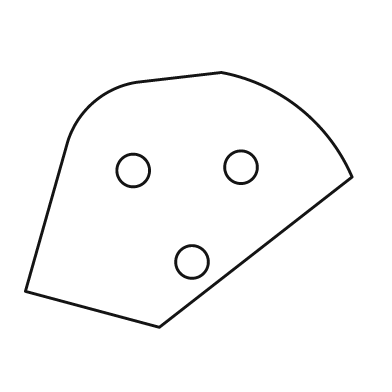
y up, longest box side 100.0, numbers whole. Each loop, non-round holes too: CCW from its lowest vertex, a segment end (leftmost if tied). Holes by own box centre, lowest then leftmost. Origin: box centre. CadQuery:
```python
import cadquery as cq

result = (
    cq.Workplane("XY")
    .moveTo(-9.0, -39.0)
    .lineTo(50.0, 7.0)
    .threePointArc((34.0, 28.0), (10.0, 39.0))
    .lineTo(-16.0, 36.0)
    .threePointArc((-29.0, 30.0), (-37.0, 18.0))
    .lineTo(-50.0, -28.0)
    .close()
    .moveTo(1.0, -19.0)
    .circle(5.0)
    .moveTo(-17.0, 9.0)
    .circle(5.0)
    .moveTo(16.0, 10.0)
    .circle(5.0)
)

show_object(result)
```